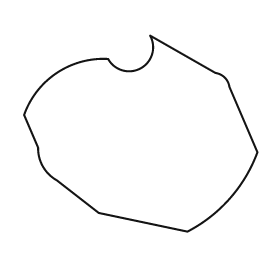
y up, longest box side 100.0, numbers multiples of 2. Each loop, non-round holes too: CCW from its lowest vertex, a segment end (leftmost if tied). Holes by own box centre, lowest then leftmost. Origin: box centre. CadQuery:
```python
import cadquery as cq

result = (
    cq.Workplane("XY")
    .moveTo(20.0, -42.0)
    .threePointArc((38.0, -28.0), (50.0, -8.0))
    .lineTo(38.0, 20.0)
    .threePointArc((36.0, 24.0), (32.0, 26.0))
    .lineTo(4.0, 42.0)
    .threePointArc((0.0, 28.0), (-14.0, 32.0))
    .threePointArc((-36.0, 26.0), (-50.0, 8.0))
    .lineTo(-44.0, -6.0)
    .threePointArc((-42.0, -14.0), (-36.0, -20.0))
    .lineTo(-18.0, -34.0)
    .close()
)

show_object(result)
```